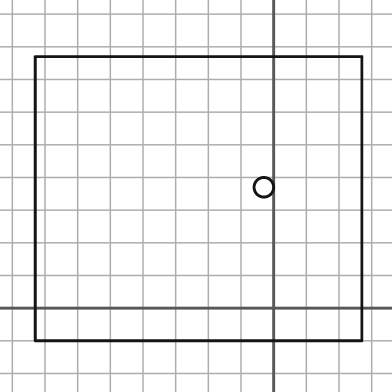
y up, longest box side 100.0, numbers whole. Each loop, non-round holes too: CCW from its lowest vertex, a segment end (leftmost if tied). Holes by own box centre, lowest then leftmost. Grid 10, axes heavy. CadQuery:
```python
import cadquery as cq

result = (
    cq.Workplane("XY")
    .moveTo(-73.0, -10.0)
    .lineTo(27.0, -10.0)
    .lineTo(27.0, 77.0)
    .lineTo(-73.0, 77.0)
    .close()
    .moveTo(-3.0, 37.0)
    .circle(3.0)
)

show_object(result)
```